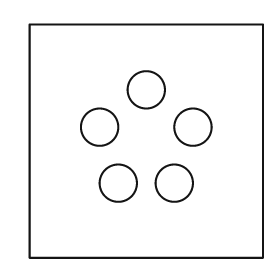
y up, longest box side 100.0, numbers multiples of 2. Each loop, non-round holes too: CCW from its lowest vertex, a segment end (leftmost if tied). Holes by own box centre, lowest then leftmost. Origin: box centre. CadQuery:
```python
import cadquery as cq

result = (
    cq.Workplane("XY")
    .moveTo(-50.0, -50.0)
    .lineTo(50.0, -50.0)
    .lineTo(50.0, 50.0)
    .lineTo(-50.0, 50.0)
    .close()
    .moveTo(-12.0, -18.0)
    .circle(8.0)
    .moveTo(12.0, -18.0)
    .circle(8.0)
    .moveTo(-20.0, 6.0)
    .circle(8.0)
    .moveTo(20.0, 6.0)
    .circle(8.0)
    .moveTo(0.0, 22.0)
    .circle(8.0)
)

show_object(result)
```